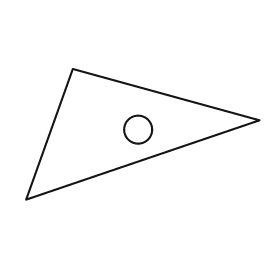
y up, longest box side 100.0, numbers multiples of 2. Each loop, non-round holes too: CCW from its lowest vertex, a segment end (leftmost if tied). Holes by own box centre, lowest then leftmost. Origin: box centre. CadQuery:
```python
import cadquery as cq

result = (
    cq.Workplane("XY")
    .moveTo(-50.0, -28.0)
    .lineTo(50.0, 6.0)
    .lineTo(-30.0, 28.0)
    .close()
    .moveTo(-2.0, 2.0)
    .circle(6.0)
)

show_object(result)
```